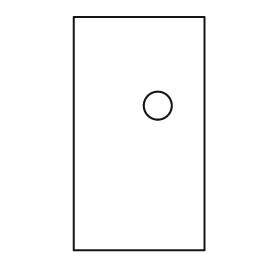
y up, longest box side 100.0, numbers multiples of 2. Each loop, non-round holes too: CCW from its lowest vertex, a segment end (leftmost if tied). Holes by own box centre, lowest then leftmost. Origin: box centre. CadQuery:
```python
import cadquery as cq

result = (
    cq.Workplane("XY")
    .moveTo(-28.0, -50.0)
    .lineTo(28.0, -50.0)
    .lineTo(28.0, 50.0)
    .lineTo(-28.0, 50.0)
    .close()
    .moveTo(8.0, 12.0)
    .circle(6.0)
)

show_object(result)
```